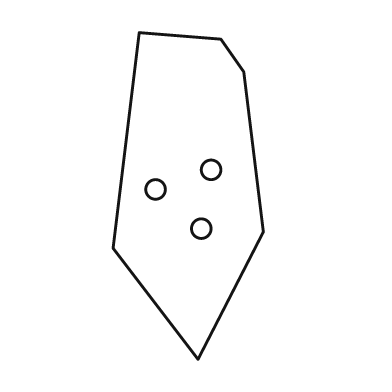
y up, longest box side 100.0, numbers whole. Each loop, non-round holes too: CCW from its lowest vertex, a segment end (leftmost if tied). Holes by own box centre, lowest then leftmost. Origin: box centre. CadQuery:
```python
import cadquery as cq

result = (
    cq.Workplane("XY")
    .moveTo(3.0, -50.0)
    .lineTo(23.0, -11.0)
    .lineTo(17.0, 38.0)
    .lineTo(10.0, 48.0)
    .lineTo(-15.0, 50.0)
    .lineTo(-23.0, -16.0)
    .close()
    .moveTo(4.0, -10.0)
    .circle(3.0)
    .moveTo(-10.0, 2.0)
    .circle(3.0)
    .moveTo(7.0, 8.0)
    .circle(3.0)
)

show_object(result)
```